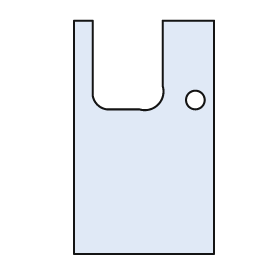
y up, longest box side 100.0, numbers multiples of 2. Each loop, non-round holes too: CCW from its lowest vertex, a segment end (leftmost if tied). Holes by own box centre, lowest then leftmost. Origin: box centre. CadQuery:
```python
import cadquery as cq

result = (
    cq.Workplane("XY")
    .moveTo(-30.0, -50.0)
    .lineTo(30.0, -50.0)
    .lineTo(30.0, 50.0)
    .lineTo(8.0, 50.0)
    .lineTo(8.0, 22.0)
    .threePointArc((6.0, 14.0), (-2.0, 12.0))
    .lineTo(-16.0, 12.0)
    .threePointArc((-20.0, 14.0), (-22.0, 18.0))
    .lineTo(-22.0, 50.0)
    .lineTo(-30.0, 50.0)
    .close()
    .moveTo(22.0, 16.0)
    .circle(4.0)
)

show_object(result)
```